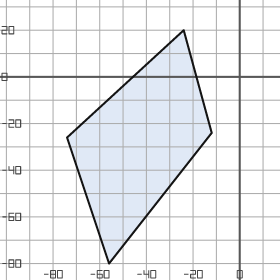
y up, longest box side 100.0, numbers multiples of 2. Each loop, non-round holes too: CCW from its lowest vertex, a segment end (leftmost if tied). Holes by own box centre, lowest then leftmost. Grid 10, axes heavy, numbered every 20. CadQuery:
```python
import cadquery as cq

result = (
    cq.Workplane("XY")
    .moveTo(-56.0, -80.0)
    .lineTo(-12.0, -24.0)
    .lineTo(-24.0, 20.0)
    .lineTo(-74.0, -26.0)
    .close()
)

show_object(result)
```